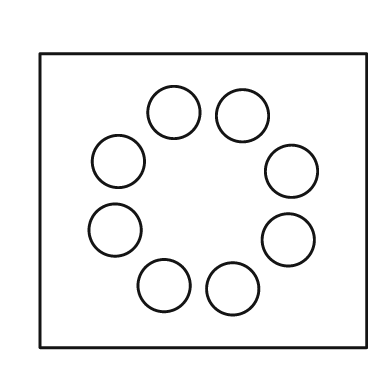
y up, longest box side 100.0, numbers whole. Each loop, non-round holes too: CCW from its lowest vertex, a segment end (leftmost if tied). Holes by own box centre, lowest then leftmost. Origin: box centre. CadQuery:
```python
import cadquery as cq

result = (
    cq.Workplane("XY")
    .moveTo(-50.0, -45.0)
    .lineTo(50.0, -45.0)
    .lineTo(50.0, 45.0)
    .lineTo(-50.0, 45.0)
    .close()
    .moveTo(9.0, -27.0)
    .circle(8.0)
    .moveTo(-12.0, -26.0)
    .circle(8.0)
    .moveTo(26.0, -12.0)
    .circle(8.0)
    .moveTo(-27.0, -9.0)
    .circle(8.0)
    .moveTo(27.0, 9.0)
    .circle(8.0)
    .moveTo(-26.0, 12.0)
    .circle(8.0)
    .moveTo(12.0, 26.0)
    .circle(8.0)
    .moveTo(-9.0, 27.0)
    .circle(8.0)
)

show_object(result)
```